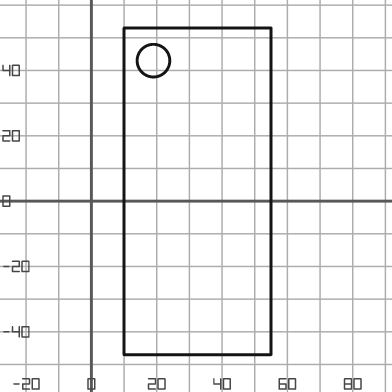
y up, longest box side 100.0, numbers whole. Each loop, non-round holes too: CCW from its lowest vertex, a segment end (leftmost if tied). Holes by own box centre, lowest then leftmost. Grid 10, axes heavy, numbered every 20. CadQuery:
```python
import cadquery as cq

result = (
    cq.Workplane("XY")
    .moveTo(10.0, -47.0)
    .lineTo(55.0, -47.0)
    .lineTo(55.0, 53.0)
    .lineTo(10.0, 53.0)
    .close()
    .moveTo(19.0, 43.0)
    .circle(5.0)
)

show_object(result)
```